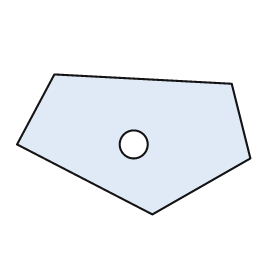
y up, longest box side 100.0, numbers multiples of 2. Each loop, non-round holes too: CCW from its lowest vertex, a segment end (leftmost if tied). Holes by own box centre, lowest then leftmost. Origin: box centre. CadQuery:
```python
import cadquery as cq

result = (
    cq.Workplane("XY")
    .moveTo(8.0, -30.0)
    .lineTo(50.0, -6.0)
    .lineTo(42.0, 26.0)
    .lineTo(-34.0, 30.0)
    .lineTo(-50.0, 0.0)
    .close()
    .moveTo(0.0, 0.0)
    .circle(6.0)
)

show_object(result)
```